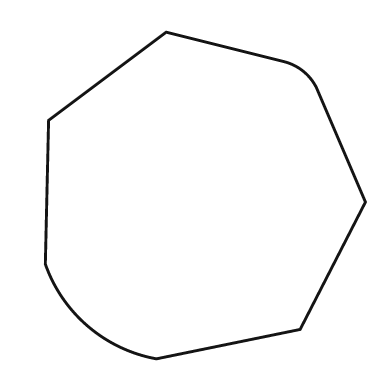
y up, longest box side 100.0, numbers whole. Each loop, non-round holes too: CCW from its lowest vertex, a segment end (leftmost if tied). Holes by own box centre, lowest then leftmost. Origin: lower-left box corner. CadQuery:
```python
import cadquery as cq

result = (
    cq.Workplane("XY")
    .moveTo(34.0, 0.0)
    .lineTo(78.0, 9.0)
    .lineTo(98.0, 48.0)
    .lineTo(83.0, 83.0)
    .threePointArc((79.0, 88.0), (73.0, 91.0))
    .lineTo(37.0, 100.0)
    .lineTo(1.0, 73.0)
    .lineTo(0.0, 29.0)
    .threePointArc((13.0, 10.0), (34.0, 0.0))
    .close()
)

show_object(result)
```